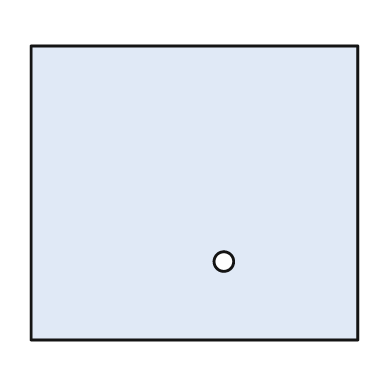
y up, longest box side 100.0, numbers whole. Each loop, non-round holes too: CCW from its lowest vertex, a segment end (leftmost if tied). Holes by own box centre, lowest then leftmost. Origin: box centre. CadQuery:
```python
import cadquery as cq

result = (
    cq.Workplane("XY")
    .moveTo(-50.0, -45.0)
    .lineTo(50.0, -45.0)
    .lineTo(50.0, 45.0)
    .lineTo(-50.0, 45.0)
    .close()
    .moveTo(9.0, -21.0)
    .circle(3.0)
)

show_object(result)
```